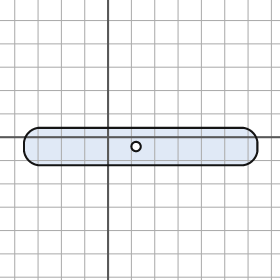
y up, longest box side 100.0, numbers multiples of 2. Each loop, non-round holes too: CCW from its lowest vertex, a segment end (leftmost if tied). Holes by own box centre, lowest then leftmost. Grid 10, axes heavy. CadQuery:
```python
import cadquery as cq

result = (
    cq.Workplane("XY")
    .moveTo(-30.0, -12.0)
    .lineTo(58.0, -12.0)
    .threePointArc((62.0, -10.0), (64.0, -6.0))
    .lineTo(64.0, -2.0)
    .threePointArc((62.0, 2.0), (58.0, 4.0))
    .lineTo(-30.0, 4.0)
    .threePointArc((-34.0, 2.0), (-36.0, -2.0))
    .lineTo(-36.0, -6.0)
    .threePointArc((-34.0, -10.0), (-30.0, -12.0))
    .close()
    .moveTo(12.0, -4.0)
    .circle(2.0)
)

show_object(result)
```